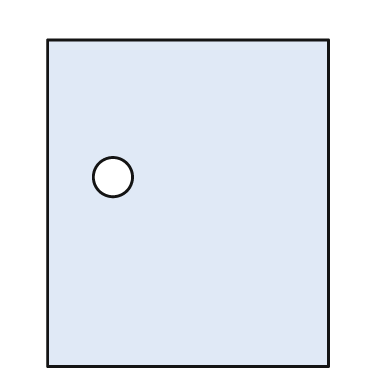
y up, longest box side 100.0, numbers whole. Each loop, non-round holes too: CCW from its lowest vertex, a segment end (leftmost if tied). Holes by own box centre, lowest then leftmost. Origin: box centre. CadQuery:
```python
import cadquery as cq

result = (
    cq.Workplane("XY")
    .moveTo(-43.0, -50.0)
    .lineTo(43.0, -50.0)
    .lineTo(43.0, 50.0)
    .lineTo(-43.0, 50.0)
    .close()
    .moveTo(-23.0, 8.0)
    .circle(6.0)
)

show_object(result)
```